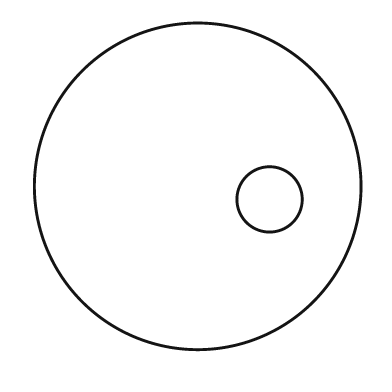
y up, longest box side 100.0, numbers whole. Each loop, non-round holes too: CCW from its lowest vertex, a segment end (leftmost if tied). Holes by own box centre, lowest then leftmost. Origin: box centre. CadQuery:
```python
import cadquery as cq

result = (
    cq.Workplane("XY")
    .moveTo(0.0, 0.0)
    .circle(50.0)
    .moveTo(22.0, -4.0)
    .circle(10.0)
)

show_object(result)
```